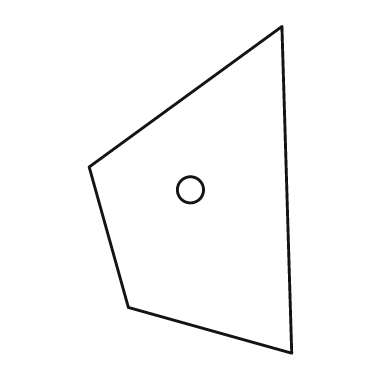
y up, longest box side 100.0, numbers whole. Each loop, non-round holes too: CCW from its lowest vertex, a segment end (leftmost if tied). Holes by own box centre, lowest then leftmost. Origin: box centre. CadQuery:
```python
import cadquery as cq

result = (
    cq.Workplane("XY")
    .moveTo(31.0, -50.0)
    .lineTo(28.0, 50.0)
    .lineTo(-31.0, 7.0)
    .lineTo(-19.0, -36.0)
    .close()
    .moveTo(0.0, 0.0)
    .circle(4.0)
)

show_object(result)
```